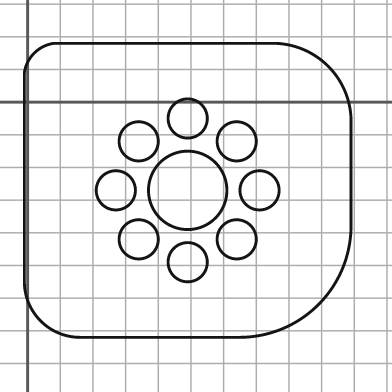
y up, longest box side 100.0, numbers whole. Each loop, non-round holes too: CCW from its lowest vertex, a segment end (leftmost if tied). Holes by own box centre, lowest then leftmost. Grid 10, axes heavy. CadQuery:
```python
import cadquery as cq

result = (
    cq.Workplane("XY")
    .moveTo(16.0, -72.0)
    .lineTo(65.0, -72.0)
    .threePointArc((89.0, -62.0), (99.0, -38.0))
    .lineTo(99.0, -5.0)
    .threePointArc((92.0, 11.0), (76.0, 18.0))
    .lineTo(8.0, 18.0)
    .threePointArc((2.0, 15.0), (-1.0, 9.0))
    .lineTo(-1.0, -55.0)
    .threePointArc((4.0, -67.0), (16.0, -72.0))
    .close()
    .moveTo(49.0, -49.0)
    .circle(6.0)
    .moveTo(34.0, -42.0)
    .circle(6.0)
    .moveTo(64.0, -42.0)
    .circle(6.0)
    .moveTo(27.0, -27.0)
    .circle(6.0)
    .moveTo(49.0, -27.0)
    .circle(12.0)
    .moveTo(71.0, -27.0)
    .circle(6.0)
    .moveTo(34.0, -12.0)
    .circle(6.0)
    .moveTo(64.0, -12.0)
    .circle(6.0)
    .moveTo(49.0, -5.0)
    .circle(6.0)
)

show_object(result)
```